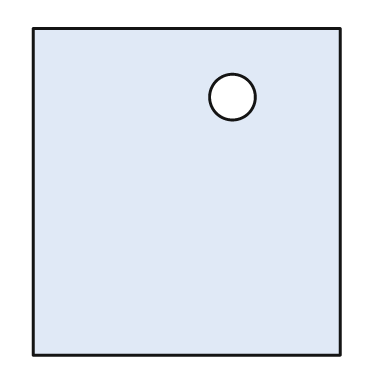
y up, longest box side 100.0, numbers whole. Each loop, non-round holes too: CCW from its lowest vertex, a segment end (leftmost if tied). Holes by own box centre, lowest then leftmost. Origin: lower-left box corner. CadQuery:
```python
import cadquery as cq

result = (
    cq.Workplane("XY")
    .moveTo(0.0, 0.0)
    .lineTo(94.0, 0.0)
    .lineTo(94.0, 100.0)
    .lineTo(0.0, 100.0)
    .close()
    .moveTo(61.0, 79.0)
    .circle(7.0)
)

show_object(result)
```